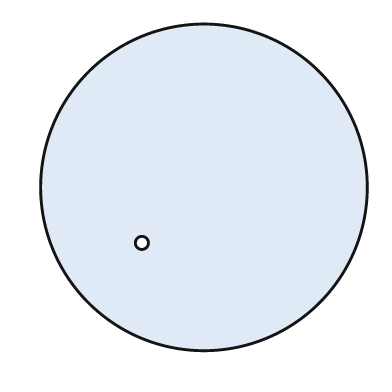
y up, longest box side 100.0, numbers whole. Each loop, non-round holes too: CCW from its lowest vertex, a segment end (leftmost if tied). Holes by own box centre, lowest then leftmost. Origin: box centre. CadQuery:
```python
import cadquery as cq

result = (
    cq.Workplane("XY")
    .moveTo(0.0, 0.0)
    .circle(50.0)
    .moveTo(-19.0, -17.0)
    .circle(2.0)
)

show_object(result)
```